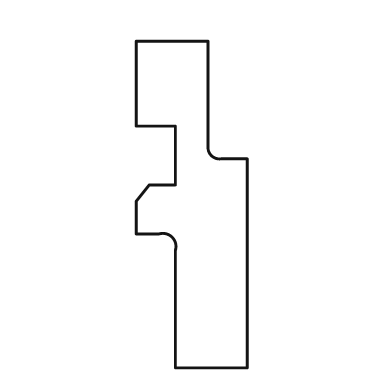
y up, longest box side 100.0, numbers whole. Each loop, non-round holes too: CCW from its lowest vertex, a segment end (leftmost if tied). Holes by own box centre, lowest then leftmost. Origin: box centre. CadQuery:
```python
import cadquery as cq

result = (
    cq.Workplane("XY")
    .moveTo(-5.0, -50.0)
    .lineTo(17.0, -50.0)
    .lineTo(17.0, 14.0)
    .lineTo(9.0, 14.0)
    .threePointArc((6.0, 15.0), (5.0, 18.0))
    .lineTo(5.0, 50.0)
    .lineTo(-17.0, 50.0)
    .lineTo(-17.0, 24.0)
    .lineTo(-5.0, 24.0)
    .lineTo(-5.0, 6.0)
    .lineTo(-13.0, 6.0)
    .lineTo(-17.0, 1.0)
    .lineTo(-17.0, -9.0)
    .lineTo(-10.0, -9.0)
    .threePointArc((-6.0, -10.0), (-5.0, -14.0))
    .close()
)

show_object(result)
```